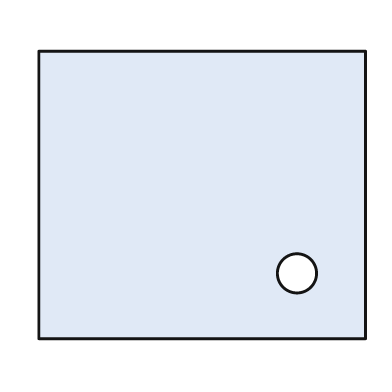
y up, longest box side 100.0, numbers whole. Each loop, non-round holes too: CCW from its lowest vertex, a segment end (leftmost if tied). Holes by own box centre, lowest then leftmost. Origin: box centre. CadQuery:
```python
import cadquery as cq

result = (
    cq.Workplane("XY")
    .moveTo(-50.0, -44.0)
    .lineTo(50.0, -44.0)
    .lineTo(50.0, 44.0)
    .lineTo(-50.0, 44.0)
    .close()
    .moveTo(29.0, -24.0)
    .circle(6.0)
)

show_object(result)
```